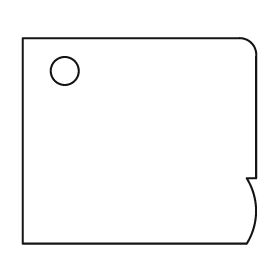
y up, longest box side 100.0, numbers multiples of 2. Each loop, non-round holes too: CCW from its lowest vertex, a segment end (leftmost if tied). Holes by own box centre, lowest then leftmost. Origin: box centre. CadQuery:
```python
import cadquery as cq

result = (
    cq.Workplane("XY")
    .moveTo(-50.0, -44.0)
    .lineTo(46.0, -44.0)
    .threePointArc((50.0, -30.0), (46.0, -16.0))
    .lineTo(50.0, -16.0)
    .lineTo(50.0, 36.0)
    .threePointArc((48.0, 42.0), (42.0, 44.0))
    .lineTo(-50.0, 44.0)
    .close()
    .moveTo(-32.0, 30.0)
    .circle(6.0)
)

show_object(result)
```